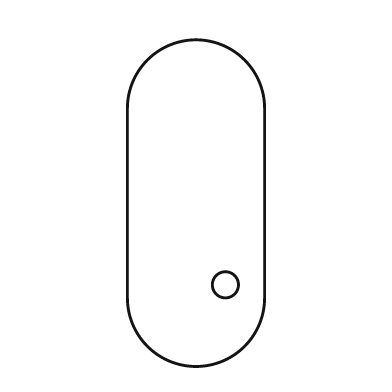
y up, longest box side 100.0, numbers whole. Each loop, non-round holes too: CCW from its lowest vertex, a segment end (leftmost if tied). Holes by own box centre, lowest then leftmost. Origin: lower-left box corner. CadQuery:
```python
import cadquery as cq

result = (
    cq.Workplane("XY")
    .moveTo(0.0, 21.0)
    .threePointArc((21.0, 0.0), (42.0, 21.0))
    .lineTo(42.0, 79.0)
    .threePointArc((21.0, 100.0), (0.0, 79.0))
    .close()
    .moveTo(30.0, 25.0)
    .circle(4.0)
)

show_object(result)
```